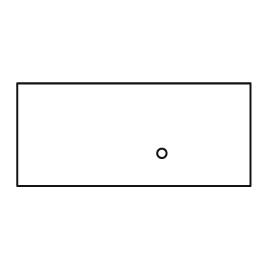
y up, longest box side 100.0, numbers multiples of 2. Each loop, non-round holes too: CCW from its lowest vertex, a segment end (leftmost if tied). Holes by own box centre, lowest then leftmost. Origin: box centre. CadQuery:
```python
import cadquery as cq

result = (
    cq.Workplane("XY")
    .moveTo(-50.0, -22.0)
    .lineTo(50.0, -22.0)
    .lineTo(50.0, 22.0)
    .lineTo(-50.0, 22.0)
    .close()
    .moveTo(12.0, -8.0)
    .circle(2.0)
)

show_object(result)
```